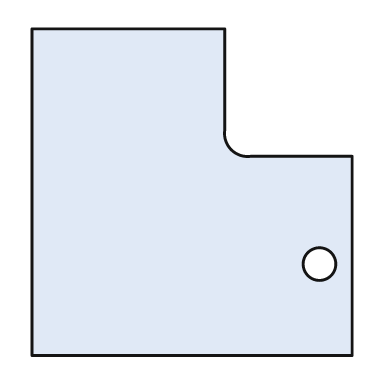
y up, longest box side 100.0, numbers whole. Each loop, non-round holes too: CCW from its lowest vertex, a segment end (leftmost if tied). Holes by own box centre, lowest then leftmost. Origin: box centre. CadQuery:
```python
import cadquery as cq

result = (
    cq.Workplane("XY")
    .moveTo(-49.0, -50.0)
    .lineTo(49.0, -50.0)
    .lineTo(49.0, 11.0)
    .lineTo(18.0, 11.0)
    .threePointArc((12.0, 13.0), (10.0, 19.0))
    .lineTo(10.0, 50.0)
    .lineTo(-49.0, 50.0)
    .close()
    .moveTo(39.0, -22.0)
    .circle(5.0)
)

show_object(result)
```